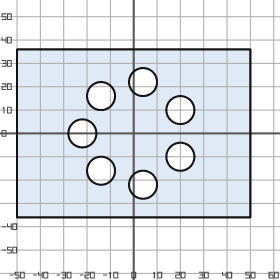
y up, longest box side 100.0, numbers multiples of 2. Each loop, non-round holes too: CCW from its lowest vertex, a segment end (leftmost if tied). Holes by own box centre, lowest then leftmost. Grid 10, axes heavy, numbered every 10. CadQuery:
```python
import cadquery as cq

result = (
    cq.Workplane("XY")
    .moveTo(-50.0, -36.0)
    .lineTo(50.0, -36.0)
    .lineTo(50.0, 36.0)
    .lineTo(-50.0, 36.0)
    .close()
    .moveTo(4.0, -22.0)
    .circle(6.0)
    .moveTo(-14.0, -16.0)
    .circle(6.0)
    .moveTo(20.0, -10.0)
    .circle(6.0)
    .moveTo(-22.0, 0.0)
    .circle(6.0)
    .moveTo(20.0, 10.0)
    .circle(6.0)
    .moveTo(-14.0, 16.0)
    .circle(6.0)
    .moveTo(4.0, 22.0)
    .circle(6.0)
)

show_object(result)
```